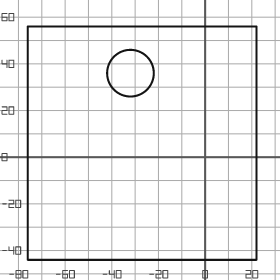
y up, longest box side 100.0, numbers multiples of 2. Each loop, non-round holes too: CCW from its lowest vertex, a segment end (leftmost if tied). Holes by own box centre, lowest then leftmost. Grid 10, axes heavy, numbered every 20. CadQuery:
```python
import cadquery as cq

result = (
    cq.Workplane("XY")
    .moveTo(-76.0, -44.0)
    .lineTo(22.0, -44.0)
    .lineTo(22.0, 56.0)
    .lineTo(-76.0, 56.0)
    .close()
    .moveTo(-32.0, 36.0)
    .circle(10.0)
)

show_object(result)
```